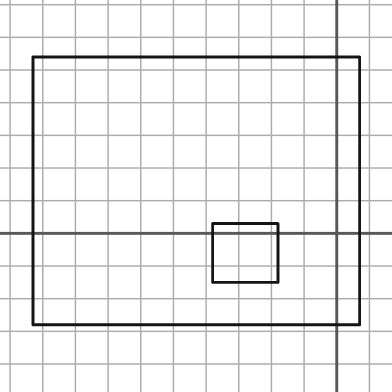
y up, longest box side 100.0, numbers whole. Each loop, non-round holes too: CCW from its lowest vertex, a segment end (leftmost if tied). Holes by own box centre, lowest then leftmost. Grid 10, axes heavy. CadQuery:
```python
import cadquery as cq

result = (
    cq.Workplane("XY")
    .moveTo(-93.0, -28.0)
    .lineTo(7.0, -28.0)
    .lineTo(7.0, 54.0)
    .lineTo(-93.0, 54.0)
    .close()
    .moveTo(-38.0, -15.0)
    .lineTo(-18.0, -15.0)
    .lineTo(-18.0, 3.0)
    .lineTo(-38.0, 3.0)
    .close()
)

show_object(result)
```